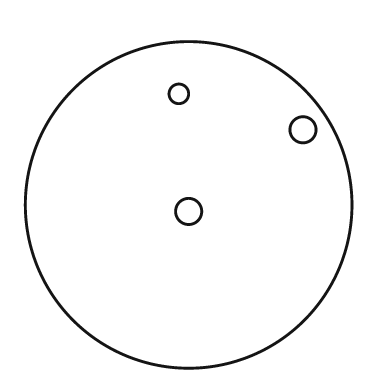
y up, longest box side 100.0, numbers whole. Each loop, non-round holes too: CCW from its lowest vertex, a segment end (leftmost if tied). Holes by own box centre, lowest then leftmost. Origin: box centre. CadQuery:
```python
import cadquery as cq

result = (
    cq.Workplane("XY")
    .moveTo(0.0, 0.0)
    .circle(50.0)
    .moveTo(0.0, -2.0)
    .circle(4.0)
    .moveTo(35.0, 23.0)
    .circle(4.0)
    .moveTo(-3.0, 34.0)
    .circle(3.0)
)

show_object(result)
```